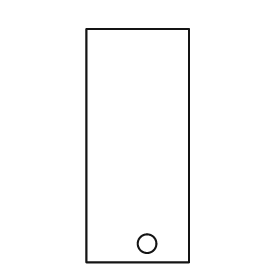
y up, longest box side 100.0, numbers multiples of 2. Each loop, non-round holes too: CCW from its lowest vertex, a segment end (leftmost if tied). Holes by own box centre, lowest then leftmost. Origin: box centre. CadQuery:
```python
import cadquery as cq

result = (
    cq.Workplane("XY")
    .moveTo(-22.0, -50.0)
    .lineTo(22.0, -50.0)
    .lineTo(22.0, 50.0)
    .lineTo(-22.0, 50.0)
    .close()
    .moveTo(4.0, -42.0)
    .circle(4.0)
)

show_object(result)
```